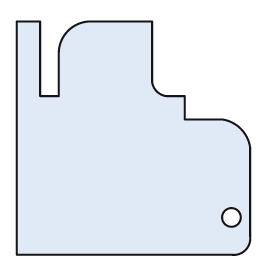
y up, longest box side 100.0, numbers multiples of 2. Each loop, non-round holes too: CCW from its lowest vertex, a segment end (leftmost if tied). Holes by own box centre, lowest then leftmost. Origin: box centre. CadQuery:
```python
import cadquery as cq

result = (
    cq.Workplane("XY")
    .moveTo(-50.0, -50.0)
    .lineTo(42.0, -50.0)
    .threePointArc((48.0, -48.0), (50.0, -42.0))
    .lineTo(50.0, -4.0)
    .threePointArc((46.0, 4.0), (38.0, 8.0))
    .lineTo(22.0, 8.0)
    .lineTo(22.0, 18.0)
    .lineTo(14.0, 18.0)
    .threePointArc((10.0, 20.0), (8.0, 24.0))
    .lineTo(8.0, 50.0)
    .lineTo(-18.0, 50.0)
    .threePointArc((-28.0, 46.0), (-32.0, 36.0))
    .lineTo(-32.0, 18.0)
    .lineTo(-40.0, 18.0)
    .lineTo(-40.0, 50.0)
    .lineTo(-50.0, 50.0)
    .close()
    .moveTo(42.0, -34.0)
    .circle(4.0)
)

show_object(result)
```